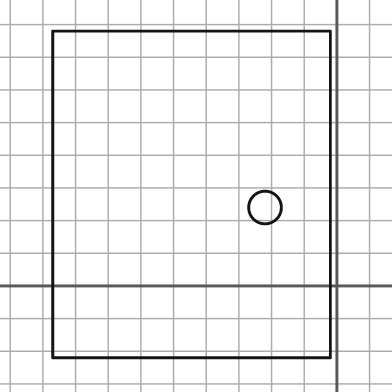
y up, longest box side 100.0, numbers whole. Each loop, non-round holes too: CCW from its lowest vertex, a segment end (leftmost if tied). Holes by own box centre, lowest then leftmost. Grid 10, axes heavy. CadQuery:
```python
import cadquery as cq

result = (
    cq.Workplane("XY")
    .moveTo(-87.0, -22.0)
    .lineTo(-2.0, -22.0)
    .lineTo(-2.0, 78.0)
    .lineTo(-87.0, 78.0)
    .close()
    .moveTo(-22.0, 24.0)
    .circle(5.0)
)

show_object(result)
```